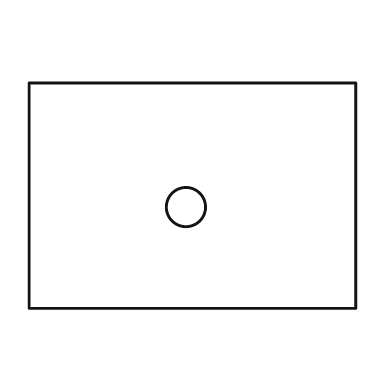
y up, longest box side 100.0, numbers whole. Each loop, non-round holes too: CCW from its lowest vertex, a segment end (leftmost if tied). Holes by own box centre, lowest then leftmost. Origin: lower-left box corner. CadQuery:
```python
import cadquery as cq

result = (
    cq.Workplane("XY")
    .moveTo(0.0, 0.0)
    .lineTo(100.0, 0.0)
    .lineTo(100.0, 69.0)
    .lineTo(0.0, 69.0)
    .close()
    .moveTo(48.0, 31.0)
    .circle(6.0)
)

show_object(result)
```